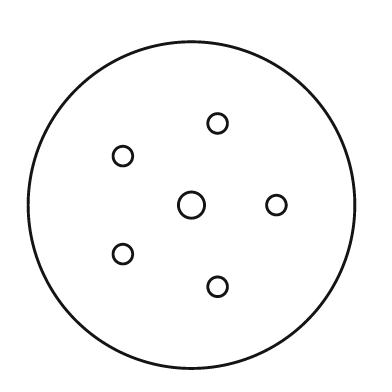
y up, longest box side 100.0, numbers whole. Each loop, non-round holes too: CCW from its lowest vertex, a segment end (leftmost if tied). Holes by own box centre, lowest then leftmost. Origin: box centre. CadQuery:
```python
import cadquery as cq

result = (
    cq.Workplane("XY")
    .moveTo(0.0, 0.0)
    .circle(50.0)
    .moveTo(8.0, -25.0)
    .circle(3.0)
    .moveTo(-21.0, -15.0)
    .circle(3.0)
    .moveTo(0.0, 0.0)
    .circle(4.0)
    .moveTo(26.0, 0.0)
    .circle(3.0)
    .moveTo(-21.0, 15.0)
    .circle(3.0)
    .moveTo(8.0, 25.0)
    .circle(3.0)
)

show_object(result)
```